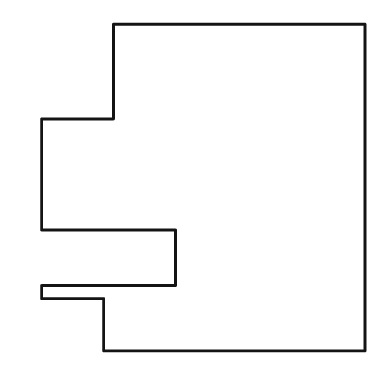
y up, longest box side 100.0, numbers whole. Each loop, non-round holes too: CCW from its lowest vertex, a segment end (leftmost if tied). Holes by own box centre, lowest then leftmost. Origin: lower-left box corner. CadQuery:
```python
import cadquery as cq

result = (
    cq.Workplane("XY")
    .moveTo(19.0, 0.0)
    .lineTo(99.0, 0.0)
    .lineTo(99.0, 100.0)
    .lineTo(22.0, 100.0)
    .lineTo(22.0, 71.0)
    .lineTo(0.0, 71.0)
    .lineTo(0.0, 37.0)
    .lineTo(41.0, 37.0)
    .lineTo(41.0, 20.0)
    .lineTo(0.0, 20.0)
    .lineTo(0.0, 16.0)
    .lineTo(19.0, 16.0)
    .close()
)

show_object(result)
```